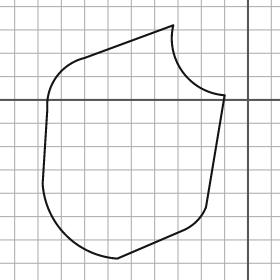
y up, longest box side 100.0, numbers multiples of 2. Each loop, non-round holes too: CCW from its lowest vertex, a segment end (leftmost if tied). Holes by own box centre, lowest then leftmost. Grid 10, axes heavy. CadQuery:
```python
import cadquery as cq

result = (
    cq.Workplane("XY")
    .moveTo(-56.0, -68.0)
    .lineTo(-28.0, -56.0)
    .threePointArc((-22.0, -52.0), (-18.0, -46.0))
    .lineTo(-10.0, 2.0)
    .threePointArc((-28.0, 12.0), (-32.0, 32.0))
    .lineTo(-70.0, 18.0)
    .threePointArc((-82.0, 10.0), (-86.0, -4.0))
    .lineTo(-88.0, -36.0)
    .threePointArc((-78.0, -58.0), (-56.0, -68.0))
    .close()
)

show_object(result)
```